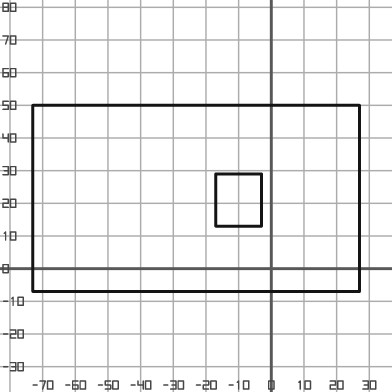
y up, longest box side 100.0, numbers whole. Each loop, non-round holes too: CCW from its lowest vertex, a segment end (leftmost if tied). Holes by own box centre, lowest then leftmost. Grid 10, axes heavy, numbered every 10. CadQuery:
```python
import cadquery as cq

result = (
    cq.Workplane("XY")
    .moveTo(-73.0, -7.0)
    .lineTo(27.0, -7.0)
    .lineTo(27.0, 50.0)
    .lineTo(-73.0, 50.0)
    .close()
    .moveTo(-17.0, 13.0)
    .lineTo(-3.0, 13.0)
    .lineTo(-3.0, 29.0)
    .lineTo(-17.0, 29.0)
    .close()
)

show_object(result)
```